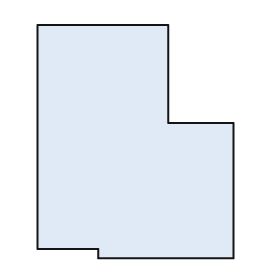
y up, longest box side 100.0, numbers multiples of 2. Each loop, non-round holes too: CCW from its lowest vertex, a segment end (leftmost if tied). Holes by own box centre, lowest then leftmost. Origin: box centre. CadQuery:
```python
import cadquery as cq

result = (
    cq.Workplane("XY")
    .moveTo(-16.0, -50.0)
    .lineTo(42.0, -50.0)
    .lineTo(42.0, 8.0)
    .lineTo(14.0, 8.0)
    .lineTo(14.0, 50.0)
    .lineTo(-42.0, 50.0)
    .lineTo(-42.0, -46.0)
    .lineTo(-16.0, -46.0)
    .close()
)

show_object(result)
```